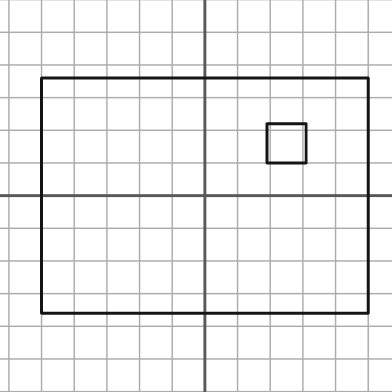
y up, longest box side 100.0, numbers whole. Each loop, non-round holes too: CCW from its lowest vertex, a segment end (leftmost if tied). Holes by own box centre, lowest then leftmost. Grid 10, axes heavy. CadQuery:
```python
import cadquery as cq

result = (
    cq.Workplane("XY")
    .moveTo(-50.0, -36.0)
    .lineTo(50.0, -36.0)
    .lineTo(50.0, 36.0)
    .lineTo(-50.0, 36.0)
    .close()
    .moveTo(19.0, 10.0)
    .lineTo(31.0, 10.0)
    .lineTo(31.0, 22.0)
    .lineTo(19.0, 22.0)
    .close()
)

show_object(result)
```